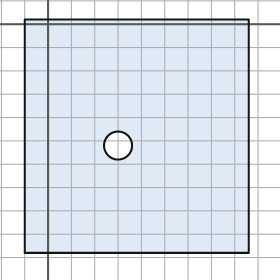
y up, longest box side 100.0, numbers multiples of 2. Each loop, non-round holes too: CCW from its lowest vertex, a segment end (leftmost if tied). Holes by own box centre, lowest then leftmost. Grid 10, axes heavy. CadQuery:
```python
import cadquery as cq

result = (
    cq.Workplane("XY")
    .moveTo(-10.0, -98.0)
    .lineTo(86.0, -98.0)
    .lineTo(86.0, 2.0)
    .lineTo(-10.0, 2.0)
    .close()
    .moveTo(30.0, -52.0)
    .circle(6.0)
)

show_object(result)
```